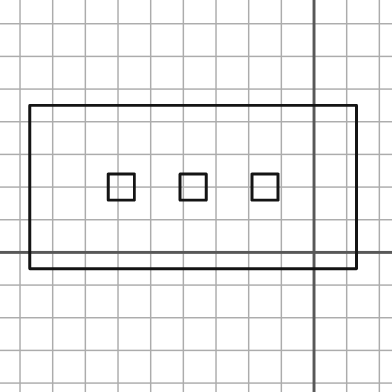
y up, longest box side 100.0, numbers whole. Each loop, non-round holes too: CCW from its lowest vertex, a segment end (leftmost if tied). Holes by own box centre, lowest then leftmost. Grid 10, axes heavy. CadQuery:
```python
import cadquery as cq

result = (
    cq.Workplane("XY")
    .moveTo(-87.0, -5.0)
    .lineTo(13.0, -5.0)
    .lineTo(13.0, 45.0)
    .lineTo(-87.0, 45.0)
    .close()
    .moveTo(-63.0, 16.0)
    .lineTo(-55.0, 16.0)
    .lineTo(-55.0, 24.0)
    .lineTo(-63.0, 24.0)
    .close()
    .moveTo(-41.0, 16.0)
    .lineTo(-33.0, 16.0)
    .lineTo(-33.0, 24.0)
    .lineTo(-41.0, 24.0)
    .close()
    .moveTo(-19.0, 16.0)
    .lineTo(-11.0, 16.0)
    .lineTo(-11.0, 24.0)
    .lineTo(-19.0, 24.0)
    .close()
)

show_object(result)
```